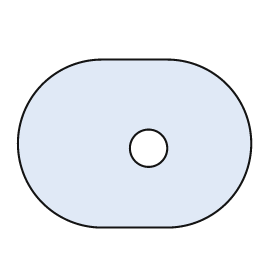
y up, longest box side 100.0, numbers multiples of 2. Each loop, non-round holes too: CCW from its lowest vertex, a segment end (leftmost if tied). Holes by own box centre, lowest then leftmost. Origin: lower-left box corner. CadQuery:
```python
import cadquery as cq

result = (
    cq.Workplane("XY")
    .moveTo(36.0, 0.0)
    .lineTo(64.0, 0.0)
    .threePointArc((100.0, 36.0), (64.0, 72.0))
    .lineTo(36.0, 72.0)
    .threePointArc((0.0, 36.0), (36.0, 0.0))
    .close()
    .moveTo(56.0, 34.0)
    .circle(8.0)
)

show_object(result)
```